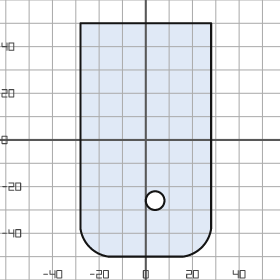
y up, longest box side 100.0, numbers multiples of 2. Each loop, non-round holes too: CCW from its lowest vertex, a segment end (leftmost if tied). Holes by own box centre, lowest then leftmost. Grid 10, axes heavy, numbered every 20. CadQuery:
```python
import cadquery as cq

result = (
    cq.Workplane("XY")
    .moveTo(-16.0, -50.0)
    .lineTo(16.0, -50.0)
    .threePointArc((24.0, -46.0), (28.0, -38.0))
    .lineTo(28.0, 50.0)
    .lineTo(-28.0, 50.0)
    .lineTo(-28.0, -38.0)
    .threePointArc((-24.0, -46.0), (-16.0, -50.0))
    .close()
    .moveTo(4.0, -26.0)
    .circle(4.0)
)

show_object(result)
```